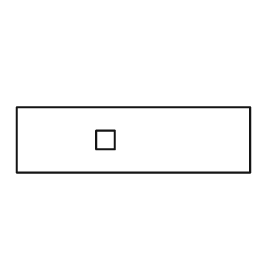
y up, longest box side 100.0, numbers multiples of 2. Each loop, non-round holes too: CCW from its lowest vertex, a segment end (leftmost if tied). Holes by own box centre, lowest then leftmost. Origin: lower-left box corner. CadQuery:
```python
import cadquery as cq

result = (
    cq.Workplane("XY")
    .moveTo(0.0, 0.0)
    .lineTo(100.0, 0.0)
    .lineTo(100.0, 28.0)
    .lineTo(0.0, 28.0)
    .close()
    .moveTo(34.0, 10.0)
    .lineTo(42.0, 10.0)
    .lineTo(42.0, 18.0)
    .lineTo(34.0, 18.0)
    .close()
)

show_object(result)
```